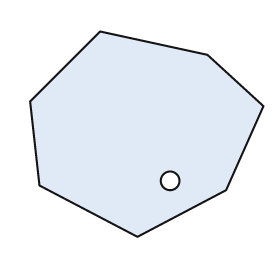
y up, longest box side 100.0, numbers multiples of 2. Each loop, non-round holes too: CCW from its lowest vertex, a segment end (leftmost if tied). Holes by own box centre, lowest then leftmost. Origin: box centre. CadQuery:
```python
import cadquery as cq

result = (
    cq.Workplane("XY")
    .moveTo(-4.0, -44.0)
    .lineTo(34.0, -24.0)
    .lineTo(50.0, 12.0)
    .lineTo(26.0, 34.0)
    .lineTo(-20.0, 44.0)
    .lineTo(-50.0, 14.0)
    .lineTo(-46.0, -22.0)
    .close()
    .moveTo(10.0, -20.0)
    .circle(4.0)
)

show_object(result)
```